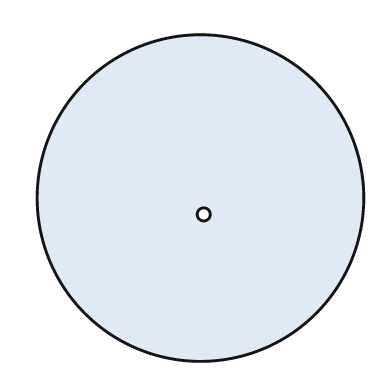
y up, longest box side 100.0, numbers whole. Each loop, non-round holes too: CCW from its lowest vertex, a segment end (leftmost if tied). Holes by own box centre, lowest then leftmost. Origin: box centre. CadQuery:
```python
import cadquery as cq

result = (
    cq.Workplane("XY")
    .moveTo(0.0, 0.0)
    .circle(50.0)
    .moveTo(1.0, -5.0)
    .circle(2.0)
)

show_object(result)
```